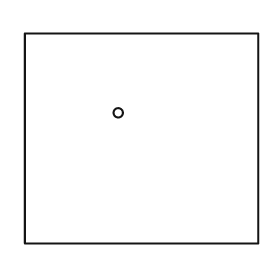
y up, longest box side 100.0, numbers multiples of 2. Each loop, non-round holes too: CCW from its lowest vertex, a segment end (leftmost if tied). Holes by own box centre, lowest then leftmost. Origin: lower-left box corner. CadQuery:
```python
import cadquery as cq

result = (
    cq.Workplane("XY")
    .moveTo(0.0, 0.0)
    .lineTo(100.0, 0.0)
    .lineTo(100.0, 90.0)
    .lineTo(0.0, 90.0)
    .close()
    .moveTo(40.0, 56.0)
    .circle(2.0)
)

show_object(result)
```